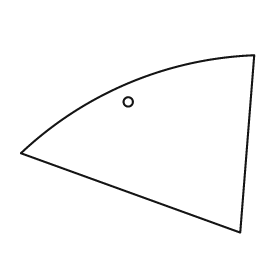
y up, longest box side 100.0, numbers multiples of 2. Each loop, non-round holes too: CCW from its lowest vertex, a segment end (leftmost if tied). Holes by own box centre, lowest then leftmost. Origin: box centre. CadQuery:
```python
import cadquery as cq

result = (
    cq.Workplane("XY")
    .moveTo(44.0, -38.0)
    .lineTo(50.0, 38.0)
    .threePointArc((-4.0, 26.0), (-50.0, -4.0))
    .close()
    .moveTo(-4.0, 18.0)
    .circle(2.0)
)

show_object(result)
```